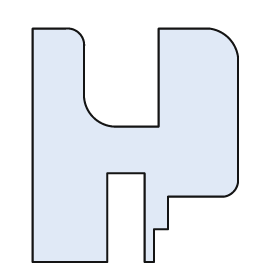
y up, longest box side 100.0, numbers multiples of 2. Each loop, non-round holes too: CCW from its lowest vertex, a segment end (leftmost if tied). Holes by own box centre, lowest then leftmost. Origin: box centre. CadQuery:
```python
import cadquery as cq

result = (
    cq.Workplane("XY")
    .moveTo(-44.0, -50.0)
    .lineTo(-12.0, -50.0)
    .lineTo(-12.0, -12.0)
    .lineTo(4.0, -12.0)
    .lineTo(4.0, -50.0)
    .lineTo(8.0, -50.0)
    .lineTo(8.0, -36.0)
    .lineTo(14.0, -36.0)
    .lineTo(14.0, -22.0)
    .lineTo(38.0, -22.0)
    .threePointArc((42.0, -20.0), (44.0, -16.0))
    .lineTo(44.0, 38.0)
    .threePointArc((40.0, 46.0), (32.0, 50.0))
    .lineTo(10.0, 50.0)
    .lineTo(10.0, 8.0)
    .lineTo(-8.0, 8.0)
    .threePointArc((-18.0, 12.0), (-22.0, 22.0))
    .lineTo(-22.0, 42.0)
    .threePointArc((-24.0, 48.0), (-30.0, 50.0))
    .lineTo(-44.0, 50.0)
    .close()
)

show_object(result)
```